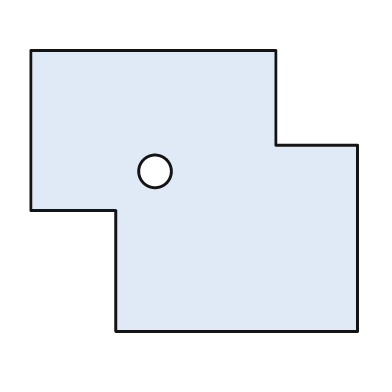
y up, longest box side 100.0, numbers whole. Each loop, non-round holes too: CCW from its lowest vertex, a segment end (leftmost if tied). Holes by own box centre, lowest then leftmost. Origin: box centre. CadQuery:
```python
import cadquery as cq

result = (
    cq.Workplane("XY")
    .moveTo(-24.0, -43.0)
    .lineTo(50.0, -43.0)
    .lineTo(50.0, 14.0)
    .lineTo(25.0, 14.0)
    .lineTo(25.0, 43.0)
    .lineTo(-50.0, 43.0)
    .lineTo(-50.0, -6.0)
    .lineTo(-24.0, -6.0)
    .close()
    .moveTo(-12.0, 6.0)
    .circle(5.0)
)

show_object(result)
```